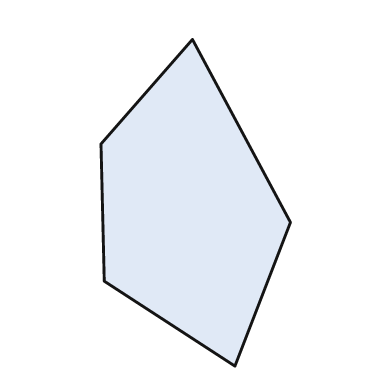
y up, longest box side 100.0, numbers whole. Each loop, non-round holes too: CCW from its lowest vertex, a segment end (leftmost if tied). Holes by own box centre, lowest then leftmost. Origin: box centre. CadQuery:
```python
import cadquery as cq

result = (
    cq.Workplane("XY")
    .moveTo(12.0, -50.0)
    .lineTo(29.0, -6.0)
    .lineTo(-1.0, 50.0)
    .lineTo(-29.0, 18.0)
    .lineTo(-28.0, -24.0)
    .close()
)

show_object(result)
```